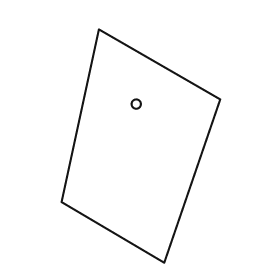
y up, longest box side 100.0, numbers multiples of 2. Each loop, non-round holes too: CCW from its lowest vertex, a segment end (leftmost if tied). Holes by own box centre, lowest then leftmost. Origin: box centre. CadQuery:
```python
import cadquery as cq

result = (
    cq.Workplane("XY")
    .moveTo(10.0, -50.0)
    .lineTo(34.0, 20.0)
    .lineTo(-18.0, 50.0)
    .lineTo(-34.0, -24.0)
    .close()
    .moveTo(-2.0, 18.0)
    .circle(2.0)
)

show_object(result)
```